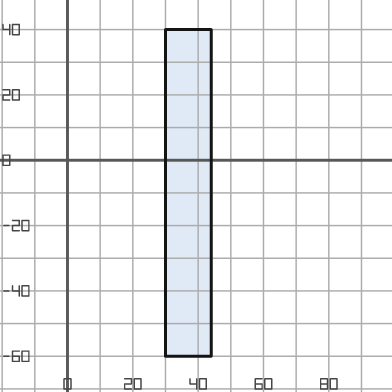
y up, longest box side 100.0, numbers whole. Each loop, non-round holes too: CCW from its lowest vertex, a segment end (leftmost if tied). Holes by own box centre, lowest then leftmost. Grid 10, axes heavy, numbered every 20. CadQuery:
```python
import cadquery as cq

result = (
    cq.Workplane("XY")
    .moveTo(30.0, -60.0)
    .lineTo(44.0, -60.0)
    .lineTo(44.0, 40.0)
    .lineTo(30.0, 40.0)
    .close()
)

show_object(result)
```